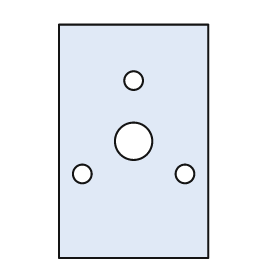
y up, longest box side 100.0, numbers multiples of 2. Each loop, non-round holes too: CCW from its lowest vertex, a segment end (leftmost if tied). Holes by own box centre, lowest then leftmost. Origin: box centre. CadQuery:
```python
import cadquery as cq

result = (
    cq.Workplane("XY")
    .moveTo(-32.0, -50.0)
    .lineTo(32.0, -50.0)
    .lineTo(32.0, 50.0)
    .lineTo(-32.0, 50.0)
    .close()
    .moveTo(-22.0, -14.0)
    .circle(4.0)
    .moveTo(22.0, -14.0)
    .circle(4.0)
    .moveTo(0.0, 0.0)
    .circle(8.0)
    .moveTo(0.0, 26.0)
    .circle(4.0)
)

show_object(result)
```